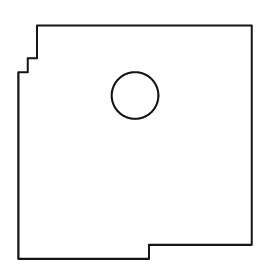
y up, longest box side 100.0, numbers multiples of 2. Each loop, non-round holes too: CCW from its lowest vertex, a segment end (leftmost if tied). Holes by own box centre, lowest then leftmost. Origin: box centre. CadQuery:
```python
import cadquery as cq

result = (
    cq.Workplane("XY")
    .moveTo(-50.0, -50.0)
    .lineTo(6.0, -50.0)
    .lineTo(6.0, -44.0)
    .lineTo(50.0, -44.0)
    .lineTo(50.0, 50.0)
    .lineTo(-42.0, 50.0)
    .lineTo(-42.0, 36.0)
    .lineTo(-46.0, 36.0)
    .lineTo(-46.0, 30.0)
    .lineTo(-50.0, 30.0)
    .close()
    .moveTo(0.0, 20.0)
    .circle(10.0)
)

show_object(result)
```